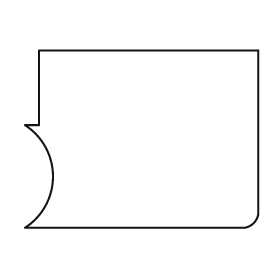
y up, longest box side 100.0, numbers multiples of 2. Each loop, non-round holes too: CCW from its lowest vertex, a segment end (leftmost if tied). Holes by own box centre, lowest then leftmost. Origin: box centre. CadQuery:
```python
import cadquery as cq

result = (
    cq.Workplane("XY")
    .moveTo(-50.0, -38.0)
    .lineTo(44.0, -38.0)
    .threePointArc((48.0, -36.0), (50.0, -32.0))
    .lineTo(50.0, 38.0)
    .lineTo(-44.0, 38.0)
    .lineTo(-44.0, 6.0)
    .lineTo(-50.0, 6.0)
    .threePointArc((-38.0, -16.0), (-50.0, -38.0))
    .close()
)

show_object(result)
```